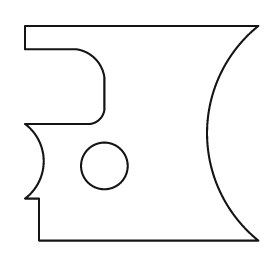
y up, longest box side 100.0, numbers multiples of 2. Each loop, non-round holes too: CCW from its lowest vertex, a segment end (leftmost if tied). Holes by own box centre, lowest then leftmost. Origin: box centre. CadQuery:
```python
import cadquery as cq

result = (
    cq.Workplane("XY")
    .moveTo(-44.0, -46.0)
    .lineTo(50.0, -46.0)
    .threePointArc((28.0, 0.0), (50.0, 46.0))
    .lineTo(-50.0, 46.0)
    .lineTo(-50.0, 36.0)
    .lineTo(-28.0, 36.0)
    .threePointArc((-20.0, 32.0), (-16.0, 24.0))
    .lineTo(-16.0, 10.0)
    .threePointArc((-18.0, 6.0), (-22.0, 4.0))
    .lineTo(-50.0, 4.0)
    .threePointArc((-42.0, -12.0), (-50.0, -28.0))
    .lineTo(-44.0, -28.0)
    .close()
    .moveTo(-16.0, -14.0)
    .circle(10.0)
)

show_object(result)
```